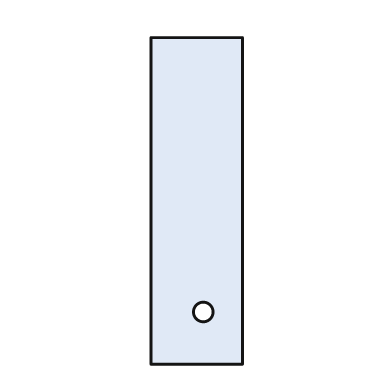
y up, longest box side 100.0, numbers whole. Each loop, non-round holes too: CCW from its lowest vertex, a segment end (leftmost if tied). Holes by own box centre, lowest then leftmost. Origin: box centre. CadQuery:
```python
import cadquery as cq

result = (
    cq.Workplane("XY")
    .moveTo(-14.0, -50.0)
    .lineTo(14.0, -50.0)
    .lineTo(14.0, 50.0)
    .lineTo(-14.0, 50.0)
    .close()
    .moveTo(2.0, -34.0)
    .circle(3.0)
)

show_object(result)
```